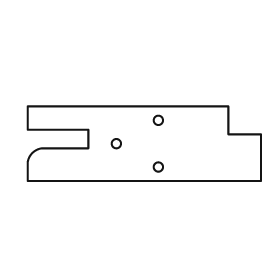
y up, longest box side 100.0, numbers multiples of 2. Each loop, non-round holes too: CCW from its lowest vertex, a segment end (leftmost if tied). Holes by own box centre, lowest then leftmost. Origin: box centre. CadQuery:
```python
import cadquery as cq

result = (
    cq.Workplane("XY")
    .moveTo(-50.0, -16.0)
    .lineTo(50.0, -16.0)
    .lineTo(50.0, 4.0)
    .lineTo(36.0, 4.0)
    .lineTo(36.0, 16.0)
    .lineTo(-50.0, 16.0)
    .lineTo(-50.0, 6.0)
    .lineTo(-24.0, 6.0)
    .lineTo(-24.0, -2.0)
    .lineTo(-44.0, -2.0)
    .threePointArc((-48.0, -4.0), (-50.0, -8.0))
    .close()
    .moveTo(6.0, -10.0)
    .circle(2.0)
    .moveTo(-12.0, 0.0)
    .circle(2.0)
    .moveTo(6.0, 10.0)
    .circle(2.0)
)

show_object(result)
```